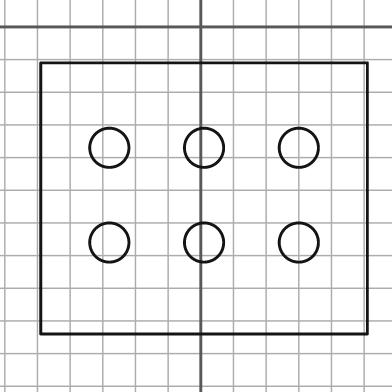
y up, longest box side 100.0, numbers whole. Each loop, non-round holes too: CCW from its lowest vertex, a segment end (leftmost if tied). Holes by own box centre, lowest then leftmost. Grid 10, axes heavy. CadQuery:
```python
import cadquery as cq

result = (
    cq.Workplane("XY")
    .moveTo(-49.0, -94.0)
    .lineTo(51.0, -94.0)
    .lineTo(51.0, -11.0)
    .lineTo(-49.0, -11.0)
    .close()
    .moveTo(-28.0, -66.0)
    .circle(6.0)
    .moveTo(1.0, -66.0)
    .circle(6.0)
    .moveTo(30.0, -66.0)
    .circle(6.0)
    .moveTo(-28.0, -37.0)
    .circle(6.0)
    .moveTo(1.0, -37.0)
    .circle(6.0)
    .moveTo(30.0, -37.0)
    .circle(6.0)
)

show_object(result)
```